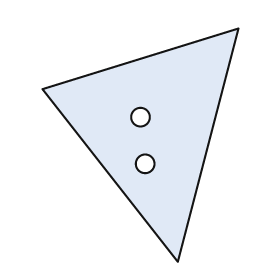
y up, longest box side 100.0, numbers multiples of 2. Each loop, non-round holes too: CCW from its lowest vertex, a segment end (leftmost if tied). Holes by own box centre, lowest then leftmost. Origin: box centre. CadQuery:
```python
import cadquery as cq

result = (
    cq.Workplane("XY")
    .moveTo(16.0, -50.0)
    .lineTo(42.0, 50.0)
    .lineTo(-42.0, 24.0)
    .close()
    .moveTo(2.0, -8.0)
    .circle(4.0)
    .moveTo(0.0, 12.0)
    .circle(4.0)
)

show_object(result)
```